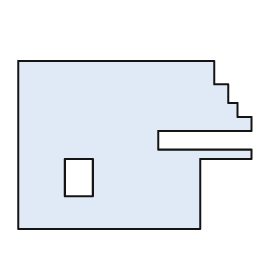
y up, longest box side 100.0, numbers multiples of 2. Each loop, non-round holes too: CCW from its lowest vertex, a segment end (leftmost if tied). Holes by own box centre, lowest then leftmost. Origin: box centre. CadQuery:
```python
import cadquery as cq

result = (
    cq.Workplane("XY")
    .moveTo(-50.0, -36.0)
    .lineTo(28.0, -36.0)
    .lineTo(28.0, -6.0)
    .lineTo(50.0, -6.0)
    .lineTo(50.0, -2.0)
    .lineTo(10.0, -2.0)
    .lineTo(10.0, 6.0)
    .lineTo(50.0, 6.0)
    .lineTo(50.0, 12.0)
    .lineTo(44.0, 12.0)
    .lineTo(44.0, 18.0)
    .lineTo(40.0, 18.0)
    .lineTo(40.0, 26.0)
    .lineTo(34.0, 26.0)
    .lineTo(34.0, 36.0)
    .lineTo(-50.0, 36.0)
    .close()
    .moveTo(-30.0, -22.0)
    .lineTo(-18.0, -22.0)
    .lineTo(-18.0, -6.0)
    .lineTo(-30.0, -6.0)
    .close()
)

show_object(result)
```